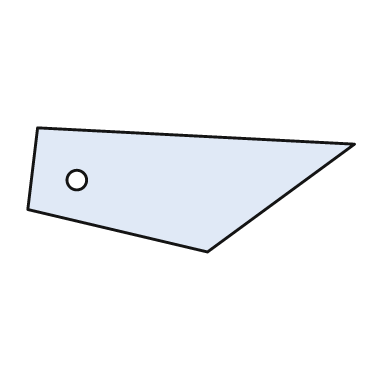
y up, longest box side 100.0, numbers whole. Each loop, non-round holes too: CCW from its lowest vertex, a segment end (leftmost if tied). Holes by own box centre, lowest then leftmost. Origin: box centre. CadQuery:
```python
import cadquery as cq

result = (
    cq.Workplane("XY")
    .moveTo(5.0, -19.0)
    .lineTo(50.0, 14.0)
    .lineTo(-47.0, 19.0)
    .lineTo(-50.0, -6.0)
    .close()
    .moveTo(-35.0, 3.0)
    .circle(3.0)
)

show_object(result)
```